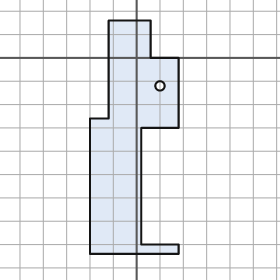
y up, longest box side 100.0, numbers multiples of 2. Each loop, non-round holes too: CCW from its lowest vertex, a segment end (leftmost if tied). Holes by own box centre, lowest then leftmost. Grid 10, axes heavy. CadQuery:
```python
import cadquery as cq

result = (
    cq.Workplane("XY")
    .moveTo(-20.0, -84.0)
    .lineTo(18.0, -84.0)
    .lineTo(18.0, -80.0)
    .lineTo(2.0, -80.0)
    .lineTo(2.0, -30.0)
    .lineTo(18.0, -30.0)
    .lineTo(18.0, 0.0)
    .lineTo(6.0, 0.0)
    .lineTo(6.0, 16.0)
    .lineTo(-12.0, 16.0)
    .lineTo(-12.0, -26.0)
    .lineTo(-20.0, -26.0)
    .close()
    .moveTo(10.0, -12.0)
    .circle(2.0)
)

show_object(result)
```